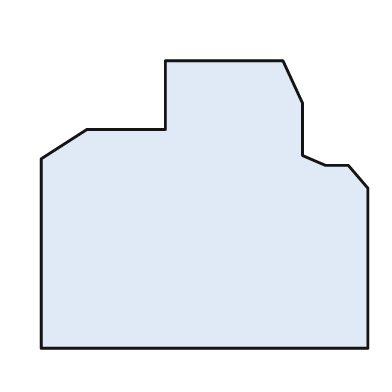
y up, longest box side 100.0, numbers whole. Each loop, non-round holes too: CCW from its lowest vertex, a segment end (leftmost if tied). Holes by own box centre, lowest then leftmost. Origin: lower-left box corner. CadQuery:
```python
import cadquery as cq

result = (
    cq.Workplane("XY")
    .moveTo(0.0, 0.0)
    .lineTo(100.0, 0.0)
    .lineTo(100.0, 49.0)
    .lineTo(94.0, 56.0)
    .lineTo(87.0, 56.0)
    .lineTo(80.0, 59.0)
    .lineTo(80.0, 75.0)
    .lineTo(74.0, 88.0)
    .lineTo(38.0, 88.0)
    .lineTo(38.0, 67.0)
    .lineTo(14.0, 67.0)
    .lineTo(0.0, 58.0)
    .close()
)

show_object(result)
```